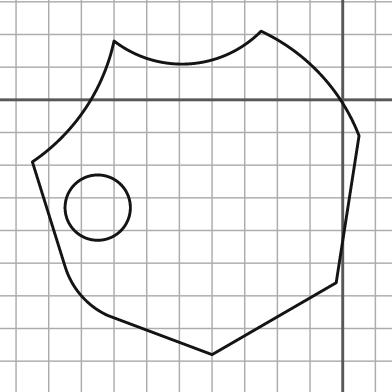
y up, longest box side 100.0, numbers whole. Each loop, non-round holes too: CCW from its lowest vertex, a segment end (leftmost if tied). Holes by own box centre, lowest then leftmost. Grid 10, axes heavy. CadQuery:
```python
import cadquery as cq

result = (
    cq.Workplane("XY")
    .moveTo(-40.0, -78.0)
    .lineTo(-2.0, -56.0)
    .lineTo(5.0, -11.0)
    .threePointArc((-7.0, 8.0), (-25.0, 21.0))
    .threePointArc((-47.0, 11.0), (-70.0, 18.0))
    .threePointArc((-79.0, -3.0), (-95.0, -19.0))
    .lineTo(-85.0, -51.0)
    .threePointArc((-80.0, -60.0), (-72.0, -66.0))
    .close()
    .moveTo(-75.0, -33.0)
    .circle(10.0)
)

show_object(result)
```